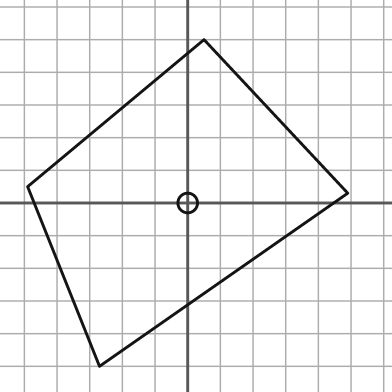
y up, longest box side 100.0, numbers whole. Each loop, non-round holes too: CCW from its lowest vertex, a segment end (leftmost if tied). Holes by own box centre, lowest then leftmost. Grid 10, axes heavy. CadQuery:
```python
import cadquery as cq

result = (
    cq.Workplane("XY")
    .moveTo(-27.0, -50.0)
    .lineTo(49.0, 3.0)
    .lineTo(5.0, 50.0)
    .lineTo(-49.0, 5.0)
    .close()
    .moveTo(0.0, 0.0)
    .circle(3.0)
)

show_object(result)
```